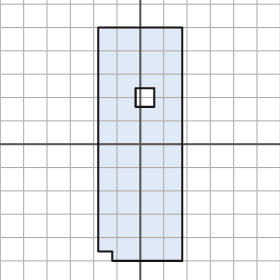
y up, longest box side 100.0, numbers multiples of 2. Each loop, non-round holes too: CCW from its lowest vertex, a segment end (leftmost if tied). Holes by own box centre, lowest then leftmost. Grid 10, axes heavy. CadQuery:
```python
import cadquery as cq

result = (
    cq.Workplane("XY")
    .moveTo(-12.0, -50.0)
    .lineTo(18.0, -50.0)
    .lineTo(18.0, 50.0)
    .lineTo(-18.0, 50.0)
    .lineTo(-18.0, -46.0)
    .lineTo(-12.0, -46.0)
    .close()
    .moveTo(-2.0, 16.0)
    .lineTo(6.0, 16.0)
    .lineTo(6.0, 24.0)
    .lineTo(-2.0, 24.0)
    .close()
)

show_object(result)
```